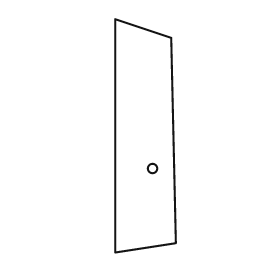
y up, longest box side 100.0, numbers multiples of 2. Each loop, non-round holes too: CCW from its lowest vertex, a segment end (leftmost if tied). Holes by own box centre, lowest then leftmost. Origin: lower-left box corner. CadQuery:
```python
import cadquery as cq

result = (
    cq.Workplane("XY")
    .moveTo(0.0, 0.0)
    .lineTo(26.0, 4.0)
    .lineTo(24.0, 92.0)
    .lineTo(0.0, 100.0)
    .close()
    .moveTo(16.0, 36.0)
    .circle(2.0)
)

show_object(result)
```